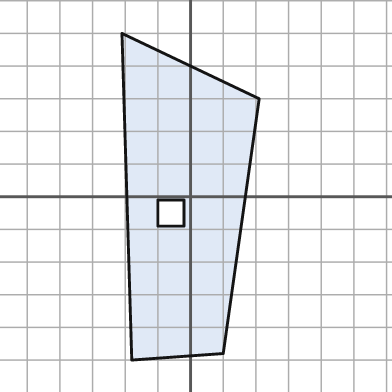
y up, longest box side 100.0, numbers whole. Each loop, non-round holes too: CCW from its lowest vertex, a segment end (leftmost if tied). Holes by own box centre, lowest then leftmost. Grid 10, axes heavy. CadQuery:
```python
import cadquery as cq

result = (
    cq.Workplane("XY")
    .moveTo(-18.0, -50.0)
    .lineTo(10.0, -48.0)
    .lineTo(21.0, 30.0)
    .lineTo(-21.0, 50.0)
    .close()
    .moveTo(-10.0, -9.0)
    .lineTo(-2.0, -9.0)
    .lineTo(-2.0, -1.0)
    .lineTo(-10.0, -1.0)
    .close()
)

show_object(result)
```